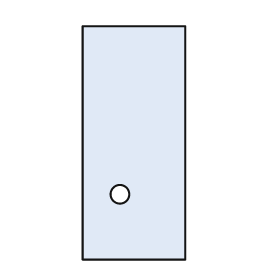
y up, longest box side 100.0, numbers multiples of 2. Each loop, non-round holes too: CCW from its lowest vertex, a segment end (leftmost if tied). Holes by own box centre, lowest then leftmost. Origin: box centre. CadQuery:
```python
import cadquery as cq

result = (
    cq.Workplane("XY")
    .moveTo(-22.0, -50.0)
    .lineTo(22.0, -50.0)
    .lineTo(22.0, 50.0)
    .lineTo(-22.0, 50.0)
    .close()
    .moveTo(-6.0, -22.0)
    .circle(4.0)
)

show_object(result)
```